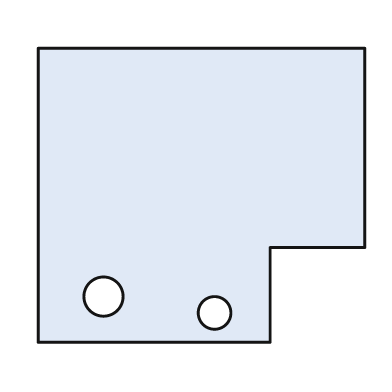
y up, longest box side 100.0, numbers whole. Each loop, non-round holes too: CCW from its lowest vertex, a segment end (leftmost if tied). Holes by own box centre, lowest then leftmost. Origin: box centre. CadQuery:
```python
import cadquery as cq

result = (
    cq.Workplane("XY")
    .moveTo(-50.0, -45.0)
    .lineTo(21.0, -45.0)
    .lineTo(21.0, -16.0)
    .lineTo(50.0, -16.0)
    .lineTo(50.0, 45.0)
    .lineTo(-50.0, 45.0)
    .close()
    .moveTo(4.0, -36.0)
    .circle(5.0)
    .moveTo(-30.0, -31.0)
    .circle(6.0)
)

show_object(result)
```